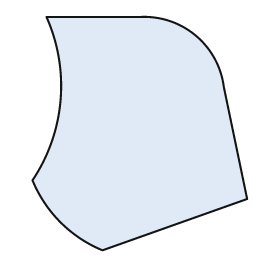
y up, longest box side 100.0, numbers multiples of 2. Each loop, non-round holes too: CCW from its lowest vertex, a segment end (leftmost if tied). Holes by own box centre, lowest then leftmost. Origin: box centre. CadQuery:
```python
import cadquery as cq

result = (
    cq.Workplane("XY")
    .moveTo(-16.0, -50.0)
    .lineTo(46.0, -28.0)
    .lineTo(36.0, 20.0)
    .threePointArc((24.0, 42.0), (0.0, 50.0))
    .lineTo(-40.0, 50.0)
    .threePointArc((-34.0, 14.0), (-46.0, -20.0))
    .threePointArc((-34.0, -38.0), (-16.0, -50.0))
    .close()
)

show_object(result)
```